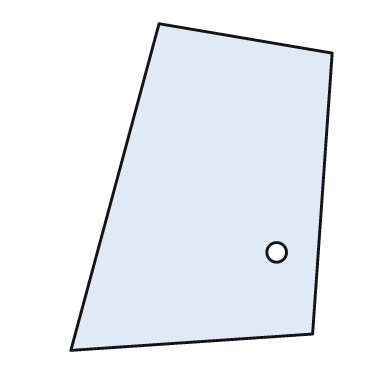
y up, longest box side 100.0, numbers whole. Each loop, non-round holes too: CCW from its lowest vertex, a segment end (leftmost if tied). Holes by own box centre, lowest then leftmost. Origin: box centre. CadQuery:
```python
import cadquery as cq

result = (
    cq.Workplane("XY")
    .moveTo(-40.0, -50.0)
    .lineTo(34.0, -45.0)
    .lineTo(40.0, 41.0)
    .lineTo(-13.0, 50.0)
    .close()
    .moveTo(23.0, -20.0)
    .circle(3.0)
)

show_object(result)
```